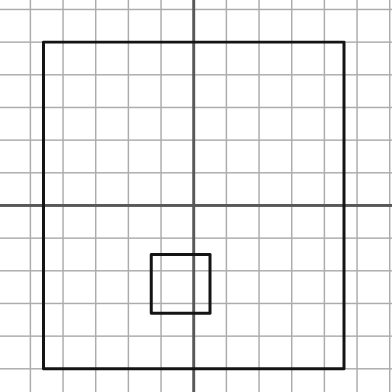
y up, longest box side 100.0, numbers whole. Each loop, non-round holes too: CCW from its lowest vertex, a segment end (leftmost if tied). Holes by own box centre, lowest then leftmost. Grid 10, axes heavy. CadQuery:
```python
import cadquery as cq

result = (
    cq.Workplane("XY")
    .moveTo(-46.0, -50.0)
    .lineTo(46.0, -50.0)
    .lineTo(46.0, 50.0)
    .lineTo(-46.0, 50.0)
    .close()
    .moveTo(-13.0, -33.0)
    .lineTo(5.0, -33.0)
    .lineTo(5.0, -15.0)
    .lineTo(-13.0, -15.0)
    .close()
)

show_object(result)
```